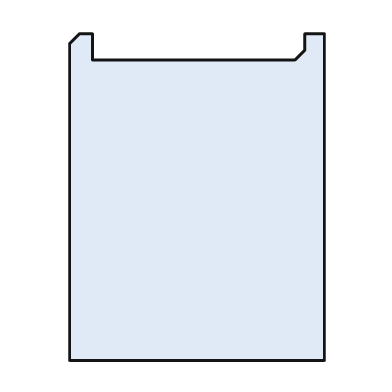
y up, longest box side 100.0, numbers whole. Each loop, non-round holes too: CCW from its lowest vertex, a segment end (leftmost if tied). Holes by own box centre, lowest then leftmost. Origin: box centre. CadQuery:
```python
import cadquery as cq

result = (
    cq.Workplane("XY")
    .moveTo(-39.0, -50.0)
    .lineTo(39.0, -50.0)
    .lineTo(39.0, 50.0)
    .lineTo(33.0, 50.0)
    .lineTo(33.0, 45.0)
    .lineTo(30.0, 42.0)
    .lineTo(-32.0, 42.0)
    .lineTo(-32.0, 50.0)
    .lineTo(-36.0, 50.0)
    .lineTo(-39.0, 47.0)
    .close()
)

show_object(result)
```